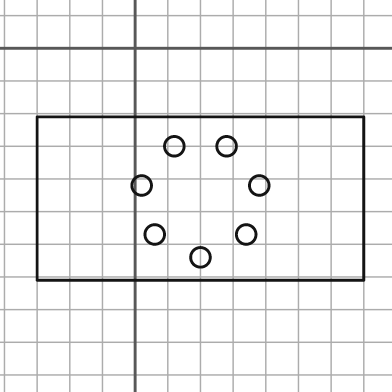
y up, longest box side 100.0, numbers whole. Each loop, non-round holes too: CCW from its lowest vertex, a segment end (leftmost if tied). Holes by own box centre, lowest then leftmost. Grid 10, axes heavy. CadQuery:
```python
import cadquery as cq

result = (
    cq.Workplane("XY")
    .moveTo(-30.0, -71.0)
    .lineTo(70.0, -71.0)
    .lineTo(70.0, -21.0)
    .lineTo(-30.0, -21.0)
    .close()
    .moveTo(20.0, -64.0)
    .circle(3.0)
    .moveTo(6.0, -57.0)
    .circle(3.0)
    .moveTo(34.0, -57.0)
    .circle(3.0)
    .moveTo(2.0, -42.0)
    .circle(3.0)
    .moveTo(38.0, -42.0)
    .circle(3.0)
    .moveTo(12.0, -30.0)
    .circle(3.0)
    .moveTo(28.0, -30.0)
    .circle(3.0)
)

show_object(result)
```